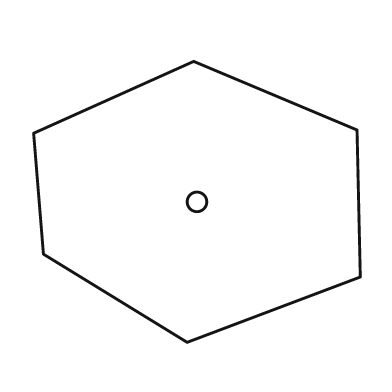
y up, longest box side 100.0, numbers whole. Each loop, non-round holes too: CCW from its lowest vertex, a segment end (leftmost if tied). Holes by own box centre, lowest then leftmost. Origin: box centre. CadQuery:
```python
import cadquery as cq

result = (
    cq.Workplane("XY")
    .moveTo(-3.0, -43.0)
    .lineTo(50.0, -23.0)
    .lineTo(49.0, 22.0)
    .lineTo(-1.0, 43.0)
    .lineTo(-50.0, 21.0)
    .lineTo(-47.0, -16.0)
    .close()
    .moveTo(0.0, 0.0)
    .circle(3.0)
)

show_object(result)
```